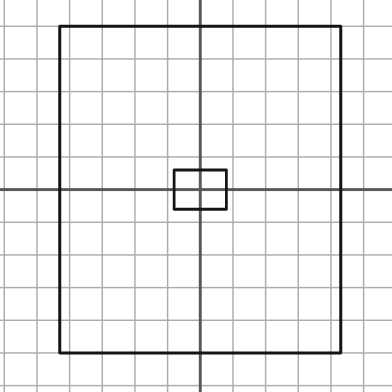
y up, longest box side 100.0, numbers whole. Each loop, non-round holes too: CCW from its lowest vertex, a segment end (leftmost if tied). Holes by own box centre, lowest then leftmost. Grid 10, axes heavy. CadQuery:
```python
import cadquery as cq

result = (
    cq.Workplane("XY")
    .moveTo(-43.0, -50.0)
    .lineTo(43.0, -50.0)
    .lineTo(43.0, 50.0)
    .lineTo(-43.0, 50.0)
    .close()
    .moveTo(-8.0, -6.0)
    .lineTo(8.0, -6.0)
    .lineTo(8.0, 6.0)
    .lineTo(-8.0, 6.0)
    .close()
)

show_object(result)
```